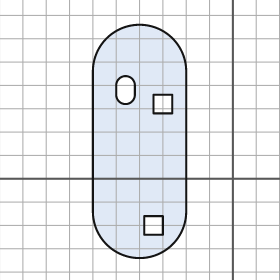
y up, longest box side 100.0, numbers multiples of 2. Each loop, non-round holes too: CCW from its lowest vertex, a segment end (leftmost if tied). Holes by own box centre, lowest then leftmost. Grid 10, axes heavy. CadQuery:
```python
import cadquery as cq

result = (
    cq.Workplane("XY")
    .moveTo(-60.0, -14.0)
    .threePointArc((-40.0, -34.0), (-20.0, -14.0))
    .lineTo(-20.0, 46.0)
    .threePointArc((-40.0, 66.0), (-60.0, 46.0))
    .close()
    .moveTo(-38.0, -24.0)
    .lineTo(-30.0, -24.0)
    .lineTo(-30.0, -16.0)
    .lineTo(-38.0, -16.0)
    .close()
    .moveTo(-34.0, 28.0)
    .lineTo(-26.0, 28.0)
    .lineTo(-26.0, 36.0)
    .lineTo(-34.0, 36.0)
    .close()
    .moveTo(-50.0, 36.0)
    .threePointArc((-46.0, 32.0), (-42.0, 36.0))
    .lineTo(-42.0, 40.0)
    .threePointArc((-46.0, 44.0), (-50.0, 40.0))
    .close()
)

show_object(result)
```